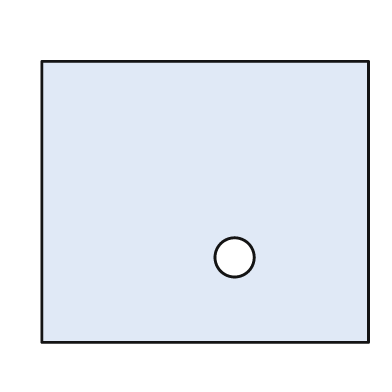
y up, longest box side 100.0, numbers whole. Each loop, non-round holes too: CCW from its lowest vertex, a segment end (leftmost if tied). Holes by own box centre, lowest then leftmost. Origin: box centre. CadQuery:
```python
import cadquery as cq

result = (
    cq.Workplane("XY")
    .moveTo(-50.0, -43.0)
    .lineTo(50.0, -43.0)
    .lineTo(50.0, 43.0)
    .lineTo(-50.0, 43.0)
    .close()
    .moveTo(9.0, -17.0)
    .circle(6.0)
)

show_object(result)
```